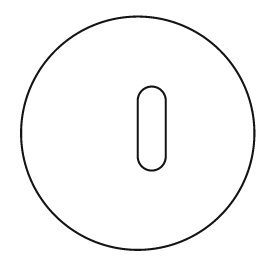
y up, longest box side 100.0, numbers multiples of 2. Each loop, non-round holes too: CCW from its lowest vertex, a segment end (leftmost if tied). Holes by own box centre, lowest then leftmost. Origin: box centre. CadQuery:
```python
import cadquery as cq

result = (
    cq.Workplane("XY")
    .moveTo(0.0, 0.0)
    .circle(50.0)
    .moveTo(0.0, -10.0)
    .threePointArc((6.0, -16.0), (12.0, -10.0))
    .lineTo(12.0, 14.0)
    .threePointArc((6.0, 20.0), (0.0, 14.0))
    .close()
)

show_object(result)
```